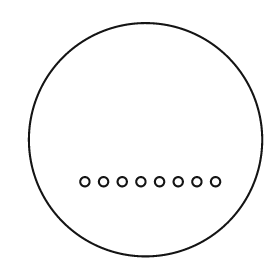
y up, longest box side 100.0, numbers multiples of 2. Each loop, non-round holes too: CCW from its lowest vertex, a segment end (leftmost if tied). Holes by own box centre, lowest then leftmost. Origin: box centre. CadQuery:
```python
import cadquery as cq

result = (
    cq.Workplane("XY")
    .moveTo(0.0, 0.0)
    .circle(50.0)
    .moveTo(-26.0, -18.0)
    .circle(2.0)
    .moveTo(-18.0, -18.0)
    .circle(2.0)
    .moveTo(-10.0, -18.0)
    .circle(2.0)
    .moveTo(-2.0, -18.0)
    .circle(2.0)
    .moveTo(6.0, -18.0)
    .circle(2.0)
    .moveTo(14.0, -18.0)
    .circle(2.0)
    .moveTo(22.0, -18.0)
    .circle(2.0)
    .moveTo(30.0, -18.0)
    .circle(2.0)
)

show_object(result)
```